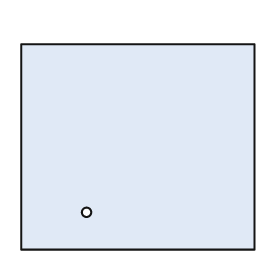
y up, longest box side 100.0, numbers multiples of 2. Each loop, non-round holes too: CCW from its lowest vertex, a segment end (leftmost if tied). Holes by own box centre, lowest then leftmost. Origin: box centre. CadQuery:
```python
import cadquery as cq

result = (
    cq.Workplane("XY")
    .moveTo(-50.0, -44.0)
    .lineTo(50.0, -44.0)
    .lineTo(50.0, 44.0)
    .lineTo(-50.0, 44.0)
    .close()
    .moveTo(-22.0, -28.0)
    .circle(2.0)
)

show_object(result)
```